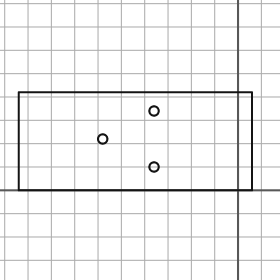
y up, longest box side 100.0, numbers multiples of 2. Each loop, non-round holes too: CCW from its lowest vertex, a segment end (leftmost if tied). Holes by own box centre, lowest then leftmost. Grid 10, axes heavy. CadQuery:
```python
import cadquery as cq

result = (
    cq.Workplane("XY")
    .moveTo(-94.0, 0.0)
    .lineTo(6.0, 0.0)
    .lineTo(6.0, 42.0)
    .lineTo(-94.0, 42.0)
    .close()
    .moveTo(-36.0, 10.0)
    .circle(2.0)
    .moveTo(-58.0, 22.0)
    .circle(2.0)
    .moveTo(-36.0, 34.0)
    .circle(2.0)
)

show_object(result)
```